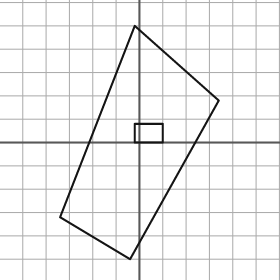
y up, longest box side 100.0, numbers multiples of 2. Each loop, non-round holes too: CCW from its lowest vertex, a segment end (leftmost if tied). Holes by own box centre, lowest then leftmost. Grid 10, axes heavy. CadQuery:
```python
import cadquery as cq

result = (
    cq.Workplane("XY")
    .moveTo(-4.0, -50.0)
    .lineTo(34.0, 18.0)
    .lineTo(-2.0, 50.0)
    .lineTo(-34.0, -32.0)
    .close()
    .moveTo(-2.0, 0.0)
    .lineTo(10.0, 0.0)
    .lineTo(10.0, 8.0)
    .lineTo(-2.0, 8.0)
    .close()
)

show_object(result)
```